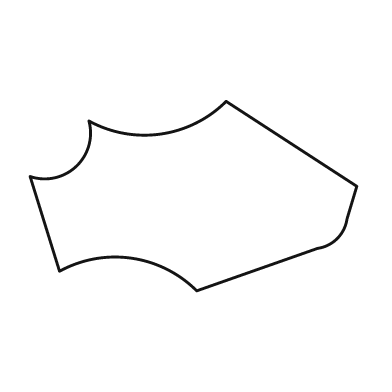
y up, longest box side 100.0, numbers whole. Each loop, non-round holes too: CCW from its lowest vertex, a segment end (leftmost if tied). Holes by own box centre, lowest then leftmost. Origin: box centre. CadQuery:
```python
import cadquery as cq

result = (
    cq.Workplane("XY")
    .moveTo(1.0, -29.0)
    .lineTo(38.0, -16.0)
    .threePointArc((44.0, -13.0), (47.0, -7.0))
    .lineTo(50.0, 3.0)
    .lineTo(10.0, 29.0)
    .threePointArc((-10.0, 19.0), (-32.0, 23.0))
    .threePointArc((-36.0, 9.0), (-50.0, 6.0))
    .lineTo(-41.0, -23.0)
    .threePointArc((-19.0, -19.0), (1.0, -29.0))
    .close()
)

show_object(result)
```